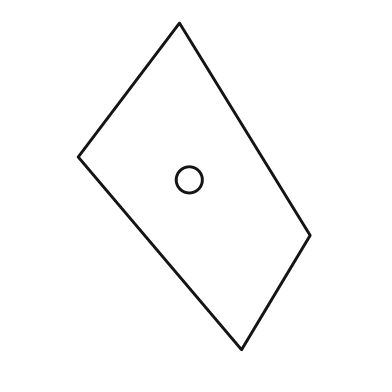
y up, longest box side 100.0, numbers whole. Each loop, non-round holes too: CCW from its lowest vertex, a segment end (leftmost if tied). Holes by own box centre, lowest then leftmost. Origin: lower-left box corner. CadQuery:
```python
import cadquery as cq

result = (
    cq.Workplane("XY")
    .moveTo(50.0, 0.0)
    .lineTo(71.0, 35.0)
    .lineTo(31.0, 100.0)
    .lineTo(0.0, 59.0)
    .close()
    .moveTo(34.0, 52.0)
    .circle(4.0)
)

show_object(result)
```